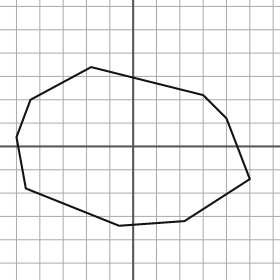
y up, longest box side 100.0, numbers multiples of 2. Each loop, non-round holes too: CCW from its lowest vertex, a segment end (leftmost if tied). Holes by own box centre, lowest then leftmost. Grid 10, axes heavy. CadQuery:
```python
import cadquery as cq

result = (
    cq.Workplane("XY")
    .moveTo(-6.0, -34.0)
    .lineTo(22.0, -32.0)
    .lineTo(50.0, -14.0)
    .lineTo(40.0, 12.0)
    .lineTo(30.0, 22.0)
    .lineTo(-18.0, 34.0)
    .lineTo(-44.0, 20.0)
    .lineTo(-50.0, 4.0)
    .lineTo(-46.0, -18.0)
    .close()
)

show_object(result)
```